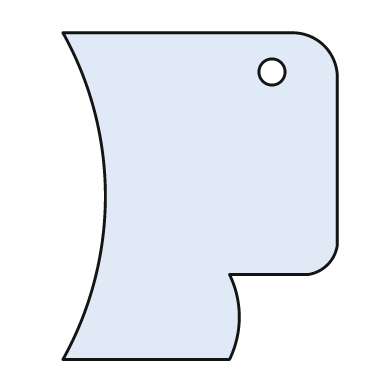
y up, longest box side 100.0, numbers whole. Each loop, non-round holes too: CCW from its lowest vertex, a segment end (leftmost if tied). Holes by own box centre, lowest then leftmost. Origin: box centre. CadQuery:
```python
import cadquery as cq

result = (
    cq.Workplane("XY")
    .moveTo(-42.0, -50.0)
    .lineTo(9.0, -50.0)
    .threePointArc((12.0, -37.0), (9.0, -24.0))
    .lineTo(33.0, -24.0)
    .threePointArc((39.0, -21.0), (42.0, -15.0))
    .lineTo(42.0, 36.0)
    .threePointArc((38.0, 46.0), (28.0, 50.0))
    .lineTo(-42.0, 50.0)
    .threePointArc((-29.0, 0.0), (-42.0, -50.0))
    .close()
    .moveTo(22.0, 38.0)
    .circle(4.0)
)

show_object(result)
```